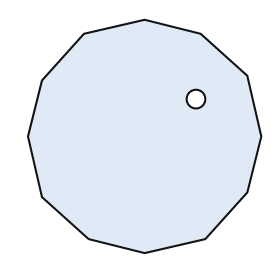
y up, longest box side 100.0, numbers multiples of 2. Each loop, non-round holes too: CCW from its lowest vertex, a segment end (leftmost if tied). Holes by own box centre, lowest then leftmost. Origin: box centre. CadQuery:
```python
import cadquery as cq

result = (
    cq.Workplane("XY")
    .moveTo(0.0, -50.0)
    .lineTo(26.0, -44.0)
    .lineTo(44.0, -24.0)
    .lineTo(50.0, 0.0)
    .lineTo(44.0, 26.0)
    .lineTo(24.0, 44.0)
    .lineTo(0.0, 50.0)
    .lineTo(-26.0, 44.0)
    .lineTo(-44.0, 24.0)
    .lineTo(-50.0, 0.0)
    .lineTo(-44.0, -26.0)
    .lineTo(-24.0, -44.0)
    .close()
    .moveTo(22.0, 16.0)
    .circle(4.0)
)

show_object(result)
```